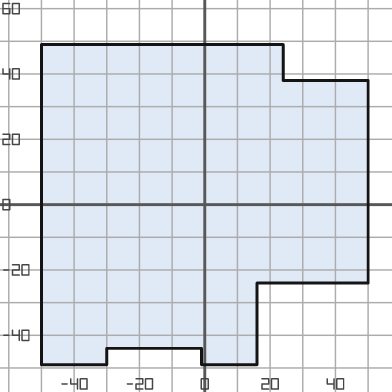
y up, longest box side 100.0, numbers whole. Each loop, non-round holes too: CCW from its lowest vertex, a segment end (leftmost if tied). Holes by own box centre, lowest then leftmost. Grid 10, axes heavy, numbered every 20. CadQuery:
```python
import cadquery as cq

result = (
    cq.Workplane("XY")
    .moveTo(-50.0, -49.0)
    .lineTo(-30.0, -49.0)
    .lineTo(-30.0, -44.0)
    .lineTo(-1.0, -44.0)
    .lineTo(-1.0, -49.0)
    .lineTo(16.0, -49.0)
    .lineTo(16.0, -24.0)
    .lineTo(50.0, -24.0)
    .lineTo(50.0, 38.0)
    .lineTo(24.0, 38.0)
    .lineTo(24.0, 49.0)
    .lineTo(-50.0, 49.0)
    .close()
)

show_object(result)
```